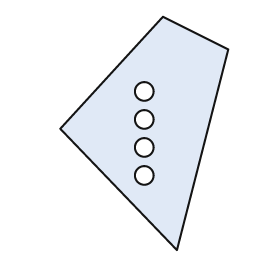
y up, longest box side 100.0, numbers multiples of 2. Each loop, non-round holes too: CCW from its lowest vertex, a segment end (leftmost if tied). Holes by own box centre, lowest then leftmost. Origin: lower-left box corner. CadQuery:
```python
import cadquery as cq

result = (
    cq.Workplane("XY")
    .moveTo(50.0, 0.0)
    .lineTo(72.0, 86.0)
    .lineTo(44.0, 100.0)
    .lineTo(0.0, 52.0)
    .close()
    .moveTo(36.0, 32.0)
    .circle(4.0)
    .moveTo(36.0, 44.0)
    .circle(4.0)
    .moveTo(36.0, 56.0)
    .circle(4.0)
    .moveTo(36.0, 68.0)
    .circle(4.0)
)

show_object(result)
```